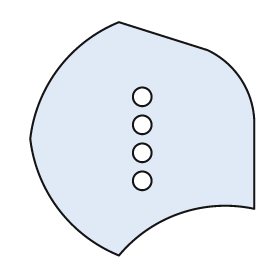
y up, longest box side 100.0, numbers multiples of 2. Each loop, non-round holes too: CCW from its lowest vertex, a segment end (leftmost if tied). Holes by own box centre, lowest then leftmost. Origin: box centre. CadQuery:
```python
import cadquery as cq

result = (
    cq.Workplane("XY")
    .moveTo(-10.0, -50.0)
    .threePointArc((16.0, -32.0), (48.0, -30.0))
    .lineTo(48.0, 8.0)
    .threePointArc((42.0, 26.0), (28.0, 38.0))
    .lineTo(-10.0, 50.0)
    .threePointArc((-36.0, 30.0), (-48.0, 0.0))
    .threePointArc((-36.0, -30.0), (-10.0, -50.0))
    .close()
    .moveTo(0.0, -18.0)
    .circle(4.0)
    .moveTo(0.0, -6.0)
    .circle(4.0)
    .moveTo(0.0, 6.0)
    .circle(4.0)
    .moveTo(0.0, 18.0)
    .circle(4.0)
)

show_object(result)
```